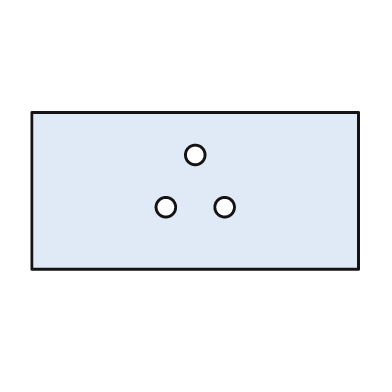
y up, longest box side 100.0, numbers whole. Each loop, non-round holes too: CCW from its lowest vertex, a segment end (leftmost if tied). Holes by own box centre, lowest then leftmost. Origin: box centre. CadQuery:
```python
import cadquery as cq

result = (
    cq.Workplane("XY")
    .moveTo(-50.0, -24.0)
    .lineTo(50.0, -24.0)
    .lineTo(50.0, 24.0)
    .lineTo(-50.0, 24.0)
    .close()
    .moveTo(-9.0, -5.0)
    .circle(3.0)
    .moveTo(9.0, -5.0)
    .circle(3.0)
    .moveTo(0.0, 11.0)
    .circle(3.0)
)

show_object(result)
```